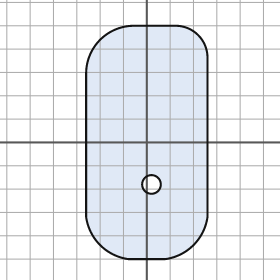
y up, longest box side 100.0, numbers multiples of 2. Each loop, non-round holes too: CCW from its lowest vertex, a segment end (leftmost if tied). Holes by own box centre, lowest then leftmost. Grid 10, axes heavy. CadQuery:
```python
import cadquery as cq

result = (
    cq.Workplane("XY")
    .moveTo(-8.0, -50.0)
    .lineTo(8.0, -50.0)
    .threePointArc((20.0, -44.0), (26.0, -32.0))
    .lineTo(26.0, 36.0)
    .threePointArc((22.0, 46.0), (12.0, 50.0))
    .lineTo(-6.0, 50.0)
    .threePointArc((-20.0, 44.0), (-26.0, 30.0))
    .lineTo(-26.0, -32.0)
    .threePointArc((-20.0, -44.0), (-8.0, -50.0))
    .close()
    .moveTo(2.0, -18.0)
    .circle(4.0)
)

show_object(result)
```